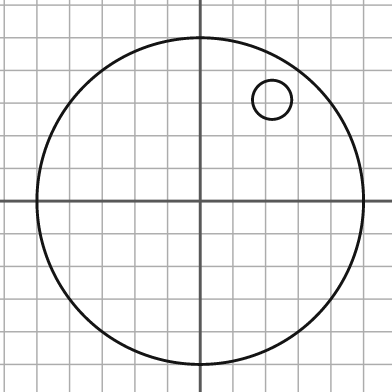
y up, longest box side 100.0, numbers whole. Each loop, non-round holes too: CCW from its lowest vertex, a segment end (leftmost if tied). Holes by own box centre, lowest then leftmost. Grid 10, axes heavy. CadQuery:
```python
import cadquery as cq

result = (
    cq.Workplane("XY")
    .moveTo(0.0, 0.0)
    .circle(50.0)
    .moveTo(22.0, 31.0)
    .circle(6.0)
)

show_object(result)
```